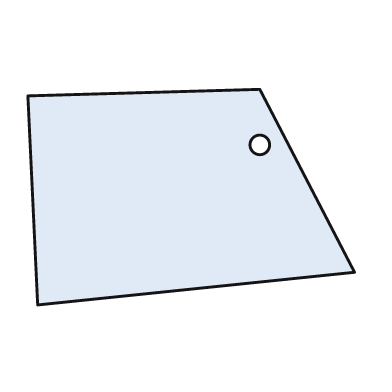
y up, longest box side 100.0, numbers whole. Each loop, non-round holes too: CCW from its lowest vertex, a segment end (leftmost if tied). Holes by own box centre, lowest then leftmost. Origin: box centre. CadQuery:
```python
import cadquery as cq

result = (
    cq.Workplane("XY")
    .moveTo(-47.0, -33.0)
    .lineTo(50.0, -23.0)
    .lineTo(21.0, 33.0)
    .lineTo(-50.0, 31.0)
    .close()
    .moveTo(21.0, 16.0)
    .circle(3.0)
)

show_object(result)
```